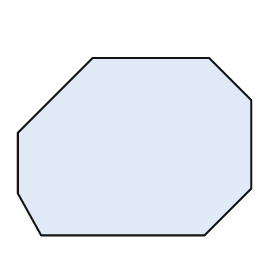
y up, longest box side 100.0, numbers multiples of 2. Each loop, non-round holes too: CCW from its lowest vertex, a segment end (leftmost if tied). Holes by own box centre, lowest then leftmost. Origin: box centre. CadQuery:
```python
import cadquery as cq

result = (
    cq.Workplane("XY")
    .moveTo(-40.0, -38.0)
    .lineTo(30.0, -38.0)
    .lineTo(50.0, -18.0)
    .lineTo(50.0, 20.0)
    .lineTo(32.0, 38.0)
    .lineTo(-18.0, 38.0)
    .lineTo(-50.0, 6.0)
    .lineTo(-50.0, -20.0)
    .close()
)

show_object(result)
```